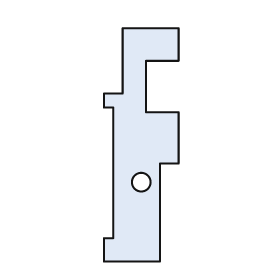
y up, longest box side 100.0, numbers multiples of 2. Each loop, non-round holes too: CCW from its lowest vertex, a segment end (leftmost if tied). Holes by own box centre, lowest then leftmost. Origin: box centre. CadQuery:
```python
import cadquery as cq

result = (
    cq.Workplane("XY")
    .moveTo(-16.0, -50.0)
    .lineTo(8.0, -50.0)
    .lineTo(8.0, -8.0)
    .lineTo(16.0, -8.0)
    .lineTo(16.0, 14.0)
    .lineTo(2.0, 14.0)
    .lineTo(2.0, 36.0)
    .lineTo(16.0, 36.0)
    .lineTo(16.0, 50.0)
    .lineTo(-8.0, 50.0)
    .lineTo(-8.0, 22.0)
    .lineTo(-16.0, 22.0)
    .lineTo(-16.0, 16.0)
    .lineTo(-12.0, 16.0)
    .lineTo(-12.0, -40.0)
    .lineTo(-16.0, -40.0)
    .close()
    .moveTo(0.0, -16.0)
    .circle(4.0)
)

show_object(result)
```